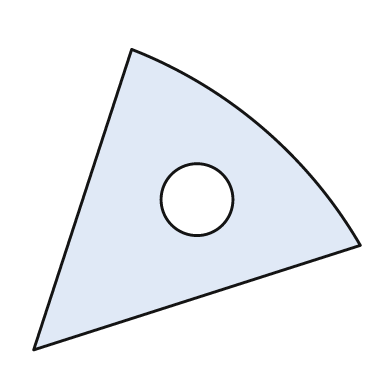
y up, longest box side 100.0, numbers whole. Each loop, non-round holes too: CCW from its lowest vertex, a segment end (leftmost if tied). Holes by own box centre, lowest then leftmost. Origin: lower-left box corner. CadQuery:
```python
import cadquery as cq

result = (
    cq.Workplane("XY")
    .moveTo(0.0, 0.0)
    .lineTo(100.0, 32.0)
    .threePointArc((70.0, 68.0), (30.0, 92.0))
    .close()
    .moveTo(50.0, 46.0)
    .circle(11.0)
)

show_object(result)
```